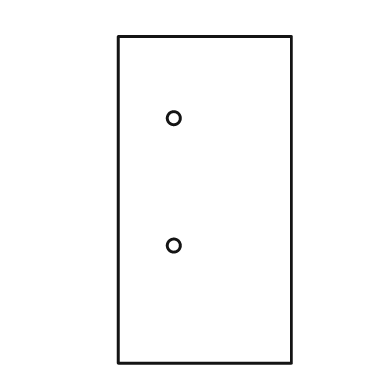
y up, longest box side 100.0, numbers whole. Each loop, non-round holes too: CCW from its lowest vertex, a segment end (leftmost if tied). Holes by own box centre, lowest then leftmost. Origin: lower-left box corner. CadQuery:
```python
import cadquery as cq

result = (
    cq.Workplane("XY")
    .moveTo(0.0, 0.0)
    .lineTo(53.0, 0.0)
    .lineTo(53.0, 100.0)
    .lineTo(0.0, 100.0)
    .close()
    .moveTo(17.0, 36.0)
    .circle(2.0)
    .moveTo(17.0, 75.0)
    .circle(2.0)
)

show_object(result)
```